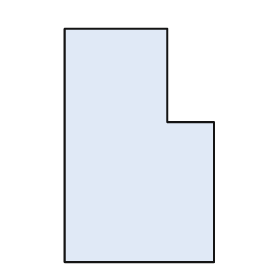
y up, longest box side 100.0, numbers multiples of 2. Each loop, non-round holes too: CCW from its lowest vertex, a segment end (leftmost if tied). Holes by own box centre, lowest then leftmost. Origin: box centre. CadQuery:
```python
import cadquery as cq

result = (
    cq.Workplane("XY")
    .moveTo(-32.0, -50.0)
    .lineTo(32.0, -50.0)
    .lineTo(32.0, 10.0)
    .lineTo(12.0, 10.0)
    .lineTo(12.0, 50.0)
    .lineTo(-32.0, 50.0)
    .close()
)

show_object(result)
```